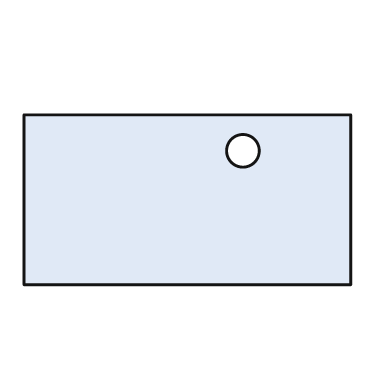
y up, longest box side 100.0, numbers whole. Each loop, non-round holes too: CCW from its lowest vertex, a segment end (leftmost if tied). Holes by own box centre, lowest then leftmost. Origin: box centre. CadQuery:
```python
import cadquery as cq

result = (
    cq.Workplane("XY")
    .moveTo(-50.0, -26.0)
    .lineTo(50.0, -26.0)
    .lineTo(50.0, 26.0)
    .lineTo(-50.0, 26.0)
    .close()
    .moveTo(17.0, 15.0)
    .circle(5.0)
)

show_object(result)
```